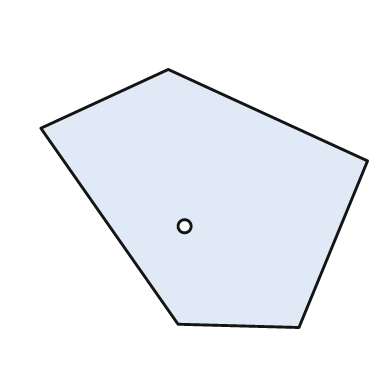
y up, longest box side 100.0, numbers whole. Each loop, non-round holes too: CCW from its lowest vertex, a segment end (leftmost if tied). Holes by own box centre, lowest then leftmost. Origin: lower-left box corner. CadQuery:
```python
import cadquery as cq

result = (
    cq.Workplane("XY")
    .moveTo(79.0, 0.0)
    .lineTo(100.0, 51.0)
    .lineTo(39.0, 79.0)
    .lineTo(0.0, 61.0)
    .lineTo(42.0, 1.0)
    .close()
    .moveTo(44.0, 31.0)
    .circle(2.0)
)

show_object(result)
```